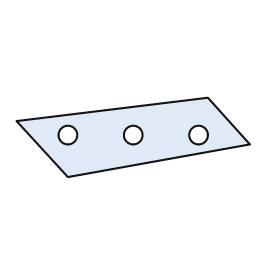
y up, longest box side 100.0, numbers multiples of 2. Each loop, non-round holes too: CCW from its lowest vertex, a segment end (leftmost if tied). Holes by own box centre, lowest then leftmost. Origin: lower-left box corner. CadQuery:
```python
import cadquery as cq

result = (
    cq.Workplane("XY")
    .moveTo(22.0, 0.0)
    .lineTo(100.0, 14.0)
    .lineTo(82.0, 34.0)
    .lineTo(0.0, 24.0)
    .close()
    .moveTo(22.0, 18.0)
    .circle(4.0)
    .moveTo(50.0, 18.0)
    .circle(4.0)
    .moveTo(78.0, 18.0)
    .circle(4.0)
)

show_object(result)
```